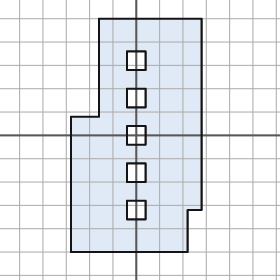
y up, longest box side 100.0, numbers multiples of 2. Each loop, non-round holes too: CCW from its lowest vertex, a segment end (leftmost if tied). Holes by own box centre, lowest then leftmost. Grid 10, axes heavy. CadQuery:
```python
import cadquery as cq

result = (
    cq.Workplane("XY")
    .moveTo(-28.0, -50.0)
    .lineTo(22.0, -50.0)
    .lineTo(22.0, -32.0)
    .lineTo(28.0, -32.0)
    .lineTo(28.0, 50.0)
    .lineTo(-16.0, 50.0)
    .lineTo(-16.0, 8.0)
    .lineTo(-28.0, 8.0)
    .close()
    .moveTo(-4.0, -36.0)
    .lineTo(4.0, -36.0)
    .lineTo(4.0, -28.0)
    .lineTo(-4.0, -28.0)
    .close()
    .moveTo(-4.0, -20.0)
    .lineTo(4.0, -20.0)
    .lineTo(4.0, -12.0)
    .lineTo(-4.0, -12.0)
    .close()
    .moveTo(-4.0, -4.0)
    .lineTo(4.0, -4.0)
    .lineTo(4.0, 4.0)
    .lineTo(-4.0, 4.0)
    .close()
    .moveTo(-4.0, 12.0)
    .lineTo(4.0, 12.0)
    .lineTo(4.0, 20.0)
    .lineTo(-4.0, 20.0)
    .close()
    .moveTo(-4.0, 28.0)
    .lineTo(4.0, 28.0)
    .lineTo(4.0, 36.0)
    .lineTo(-4.0, 36.0)
    .close()
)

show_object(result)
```